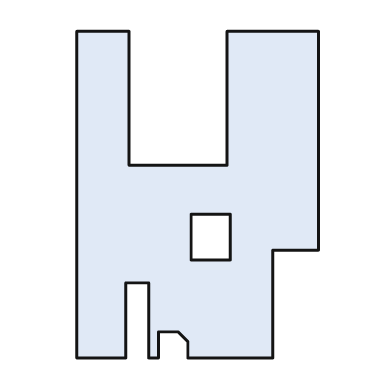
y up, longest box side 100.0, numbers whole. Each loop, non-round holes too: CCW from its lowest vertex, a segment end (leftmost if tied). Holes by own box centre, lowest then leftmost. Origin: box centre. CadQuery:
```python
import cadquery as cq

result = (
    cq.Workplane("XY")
    .moveTo(-37.0, -50.0)
    .lineTo(-22.0, -50.0)
    .lineTo(-22.0, -27.0)
    .lineTo(-15.0, -27.0)
    .lineTo(-15.0, -50.0)
    .lineTo(-12.0, -50.0)
    .lineTo(-12.0, -42.0)
    .lineTo(-6.0, -42.0)
    .lineTo(-3.0, -45.0)
    .lineTo(-3.0, -50.0)
    .lineTo(23.0, -50.0)
    .lineTo(23.0, -17.0)
    .lineTo(37.0, -17.0)
    .lineTo(37.0, 50.0)
    .lineTo(9.0, 50.0)
    .lineTo(9.0, 9.0)
    .lineTo(-21.0, 9.0)
    .lineTo(-21.0, 50.0)
    .lineTo(-37.0, 50.0)
    .close()
    .moveTo(-2.0, -20.0)
    .lineTo(10.0, -20.0)
    .lineTo(10.0, -6.0)
    .lineTo(-2.0, -6.0)
    .close()
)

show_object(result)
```